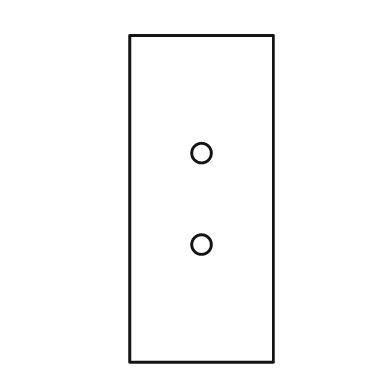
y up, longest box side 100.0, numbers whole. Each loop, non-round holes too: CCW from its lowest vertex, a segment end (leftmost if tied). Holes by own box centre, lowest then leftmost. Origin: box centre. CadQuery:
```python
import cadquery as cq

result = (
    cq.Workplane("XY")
    .moveTo(-22.0, -50.0)
    .lineTo(22.0, -50.0)
    .lineTo(22.0, 50.0)
    .lineTo(-22.0, 50.0)
    .close()
    .moveTo(0.0, -14.0)
    .circle(3.0)
    .moveTo(0.0, 14.0)
    .circle(3.0)
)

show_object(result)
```